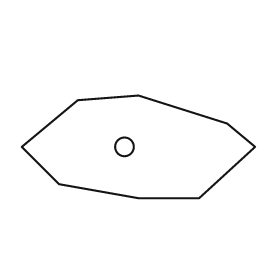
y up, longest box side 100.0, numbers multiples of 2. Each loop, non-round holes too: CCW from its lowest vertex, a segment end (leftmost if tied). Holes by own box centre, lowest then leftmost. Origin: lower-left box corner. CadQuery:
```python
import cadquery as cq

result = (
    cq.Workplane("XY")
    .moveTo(50.0, 0.0)
    .lineTo(76.0, 0.0)
    .lineTo(100.0, 22.0)
    .lineTo(88.0, 32.0)
    .lineTo(50.0, 44.0)
    .lineTo(24.0, 42.0)
    .lineTo(0.0, 22.0)
    .lineTo(16.0, 6.0)
    .close()
    .moveTo(44.0, 22.0)
    .circle(4.0)
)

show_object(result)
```